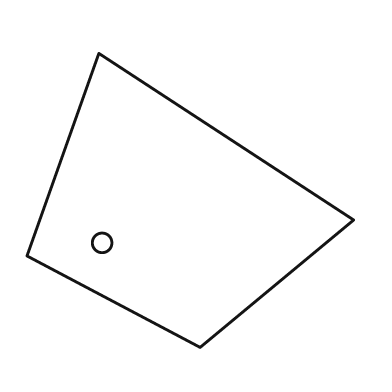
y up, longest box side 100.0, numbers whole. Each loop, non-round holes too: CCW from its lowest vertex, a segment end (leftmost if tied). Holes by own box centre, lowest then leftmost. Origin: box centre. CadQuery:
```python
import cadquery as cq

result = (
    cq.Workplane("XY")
    .moveTo(3.0, -45.0)
    .lineTo(50.0, -6.0)
    .lineTo(-28.0, 45.0)
    .lineTo(-50.0, -17.0)
    .close()
    .moveTo(-27.0, -13.0)
    .circle(3.0)
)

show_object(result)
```